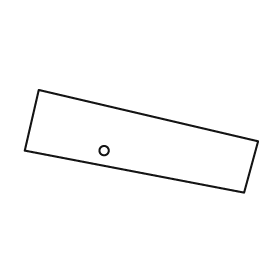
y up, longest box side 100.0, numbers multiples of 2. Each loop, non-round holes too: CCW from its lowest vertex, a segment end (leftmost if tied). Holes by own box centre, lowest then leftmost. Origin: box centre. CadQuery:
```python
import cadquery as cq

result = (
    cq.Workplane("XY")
    .moveTo(44.0, -22.0)
    .lineTo(50.0, 0.0)
    .lineTo(-44.0, 22.0)
    .lineTo(-50.0, -4.0)
    .close()
    .moveTo(-16.0, -4.0)
    .circle(2.0)
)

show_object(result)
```